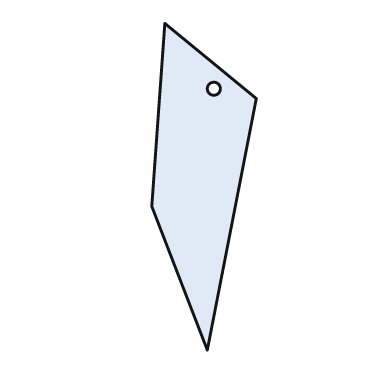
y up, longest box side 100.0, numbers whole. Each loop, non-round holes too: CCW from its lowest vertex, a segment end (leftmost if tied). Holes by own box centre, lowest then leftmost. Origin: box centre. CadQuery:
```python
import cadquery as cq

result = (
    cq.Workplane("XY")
    .moveTo(1.0, -50.0)
    .lineTo(16.0, 27.0)
    .lineTo(-12.0, 50.0)
    .lineTo(-16.0, -6.0)
    .close()
    .moveTo(3.0, 30.0)
    .circle(2.0)
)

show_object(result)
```